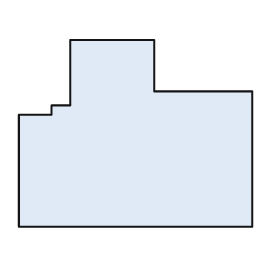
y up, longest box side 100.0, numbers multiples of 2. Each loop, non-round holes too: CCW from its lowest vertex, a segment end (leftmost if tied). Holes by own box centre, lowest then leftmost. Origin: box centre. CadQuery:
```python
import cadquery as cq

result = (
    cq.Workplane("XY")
    .moveTo(-50.0, -40.0)
    .lineTo(50.0, -40.0)
    .lineTo(50.0, 18.0)
    .lineTo(8.0, 18.0)
    .lineTo(8.0, 40.0)
    .lineTo(-28.0, 40.0)
    .lineTo(-28.0, 12.0)
    .lineTo(-36.0, 12.0)
    .lineTo(-36.0, 8.0)
    .lineTo(-50.0, 8.0)
    .close()
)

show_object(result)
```